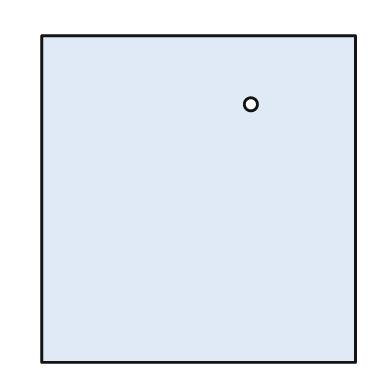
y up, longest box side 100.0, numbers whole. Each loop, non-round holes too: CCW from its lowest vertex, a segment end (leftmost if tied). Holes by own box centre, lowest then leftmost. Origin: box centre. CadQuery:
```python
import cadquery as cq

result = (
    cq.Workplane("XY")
    .moveTo(-48.0, -50.0)
    .lineTo(48.0, -50.0)
    .lineTo(48.0, 50.0)
    .lineTo(-48.0, 50.0)
    .close()
    .moveTo(16.0, 29.0)
    .circle(2.0)
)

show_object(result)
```